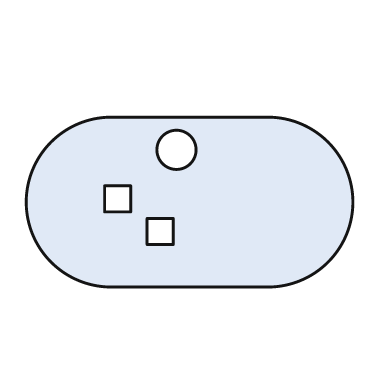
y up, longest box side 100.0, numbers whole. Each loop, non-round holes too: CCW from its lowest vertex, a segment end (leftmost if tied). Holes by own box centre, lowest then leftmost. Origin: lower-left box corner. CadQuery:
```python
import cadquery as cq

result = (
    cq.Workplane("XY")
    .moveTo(26.0, 0.0)
    .lineTo(74.0, 0.0)
    .threePointArc((100.0, 26.0), (74.0, 52.0))
    .lineTo(26.0, 52.0)
    .threePointArc((0.0, 26.0), (26.0, 0.0))
    .close()
    .moveTo(37.0, 13.0)
    .lineTo(45.0, 13.0)
    .lineTo(45.0, 21.0)
    .lineTo(37.0, 21.0)
    .close()
    .moveTo(24.0, 23.0)
    .lineTo(32.0, 23.0)
    .lineTo(32.0, 31.0)
    .lineTo(24.0, 31.0)
    .close()
    .moveTo(46.0, 42.0)
    .circle(6.0)
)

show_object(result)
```